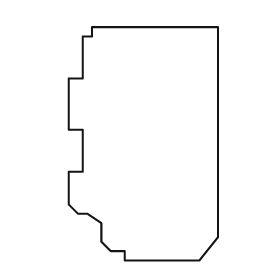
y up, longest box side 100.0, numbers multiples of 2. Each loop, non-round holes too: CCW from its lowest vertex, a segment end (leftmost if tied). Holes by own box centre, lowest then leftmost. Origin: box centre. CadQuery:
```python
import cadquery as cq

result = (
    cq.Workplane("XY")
    .moveTo(-8.0, -50.0)
    .lineTo(24.0, -50.0)
    .lineTo(32.0, -40.0)
    .lineTo(32.0, 50.0)
    .lineTo(-22.0, 50.0)
    .lineTo(-22.0, 46.0)
    .lineTo(-26.0, 46.0)
    .lineTo(-26.0, 28.0)
    .lineTo(-32.0, 28.0)
    .lineTo(-32.0, 6.0)
    .lineTo(-26.0, 6.0)
    .lineTo(-26.0, -12.0)
    .lineTo(-32.0, -12.0)
    .lineTo(-32.0, -26.0)
    .lineTo(-28.0, -30.0)
    .lineTo(-24.0, -30.0)
    .lineTo(-18.0, -34.0)
    .lineTo(-18.0, -42.0)
    .lineTo(-14.0, -46.0)
    .lineTo(-8.0, -46.0)
    .close()
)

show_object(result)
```